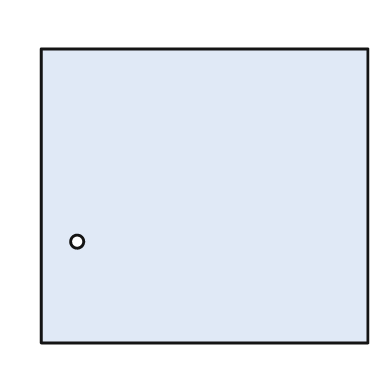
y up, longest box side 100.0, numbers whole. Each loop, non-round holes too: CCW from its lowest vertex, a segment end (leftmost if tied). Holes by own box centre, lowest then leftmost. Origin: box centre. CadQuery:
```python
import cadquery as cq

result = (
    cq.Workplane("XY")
    .moveTo(-50.0, -45.0)
    .lineTo(50.0, -45.0)
    .lineTo(50.0, 45.0)
    .lineTo(-50.0, 45.0)
    .close()
    .moveTo(-39.0, -14.0)
    .circle(2.0)
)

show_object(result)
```